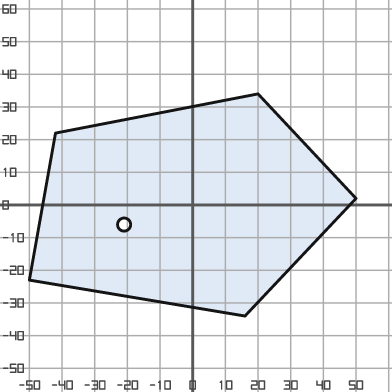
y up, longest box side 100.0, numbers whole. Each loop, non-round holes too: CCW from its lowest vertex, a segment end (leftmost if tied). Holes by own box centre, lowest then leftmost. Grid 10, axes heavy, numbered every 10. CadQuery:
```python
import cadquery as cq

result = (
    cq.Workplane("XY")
    .moveTo(16.0, -34.0)
    .lineTo(50.0, 2.0)
    .lineTo(20.0, 34.0)
    .lineTo(-42.0, 22.0)
    .lineTo(-50.0, -23.0)
    .close()
    .moveTo(-21.0, -6.0)
    .circle(2.0)
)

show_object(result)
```